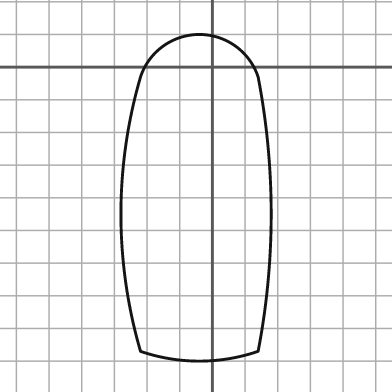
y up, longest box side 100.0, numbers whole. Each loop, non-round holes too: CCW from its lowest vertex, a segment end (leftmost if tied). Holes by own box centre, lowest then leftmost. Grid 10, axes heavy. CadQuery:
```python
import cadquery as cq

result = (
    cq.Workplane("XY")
    .moveTo(-22.0, -87.0)
    .threePointArc((-4.0, -90.0), (14.0, -87.0))
    .threePointArc((18.0, -45.0), (14.0, -3.0))
    .threePointArc((-4.0, 10.0), (-22.0, -3.0))
    .threePointArc((-28.0, -45.0), (-22.0, -87.0))
    .close()
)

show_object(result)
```